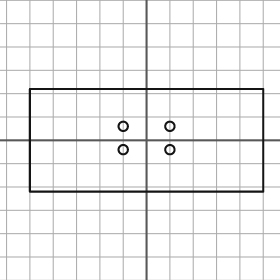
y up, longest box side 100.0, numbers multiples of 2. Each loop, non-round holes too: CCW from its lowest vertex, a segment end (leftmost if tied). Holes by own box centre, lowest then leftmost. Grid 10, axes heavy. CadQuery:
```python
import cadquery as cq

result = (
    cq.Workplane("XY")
    .moveTo(-50.0, -22.0)
    .lineTo(50.0, -22.0)
    .lineTo(50.0, 22.0)
    .lineTo(-50.0, 22.0)
    .close()
    .moveTo(-10.0, -4.0)
    .circle(2.0)
    .moveTo(10.0, -4.0)
    .circle(2.0)
    .moveTo(-10.0, 6.0)
    .circle(2.0)
    .moveTo(10.0, 6.0)
    .circle(2.0)
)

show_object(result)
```